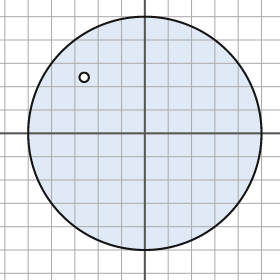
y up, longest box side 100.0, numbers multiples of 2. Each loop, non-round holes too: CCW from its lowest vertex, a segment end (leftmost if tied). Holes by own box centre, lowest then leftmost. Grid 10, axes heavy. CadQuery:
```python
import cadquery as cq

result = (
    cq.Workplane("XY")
    .moveTo(0.0, 0.0)
    .circle(50.0)
    .moveTo(-26.0, 24.0)
    .circle(2.0)
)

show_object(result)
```